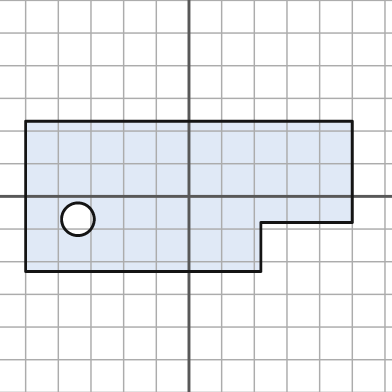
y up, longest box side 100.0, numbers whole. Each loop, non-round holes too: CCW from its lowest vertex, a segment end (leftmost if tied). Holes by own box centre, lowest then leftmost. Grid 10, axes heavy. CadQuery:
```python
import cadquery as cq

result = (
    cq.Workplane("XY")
    .moveTo(-50.0, -23.0)
    .lineTo(22.0, -23.0)
    .lineTo(22.0, -8.0)
    .lineTo(50.0, -8.0)
    .lineTo(50.0, 23.0)
    .lineTo(-50.0, 23.0)
    .close()
    .moveTo(-34.0, -7.0)
    .circle(5.0)
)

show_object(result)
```